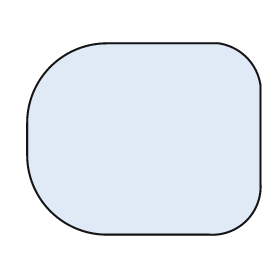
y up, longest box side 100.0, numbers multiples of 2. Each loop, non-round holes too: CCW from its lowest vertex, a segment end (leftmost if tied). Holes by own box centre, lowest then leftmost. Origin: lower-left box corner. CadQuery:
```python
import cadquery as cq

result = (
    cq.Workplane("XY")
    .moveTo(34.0, 0.0)
    .lineTo(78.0, 0.0)
    .threePointArc((94.0, 6.0), (100.0, 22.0))
    .lineTo(100.0, 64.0)
    .threePointArc((94.0, 76.0), (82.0, 82.0))
    .lineTo(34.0, 82.0)
    .threePointArc((10.0, 72.0), (0.0, 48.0))
    .lineTo(0.0, 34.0)
    .threePointArc((10.0, 10.0), (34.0, 0.0))
    .close()
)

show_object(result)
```